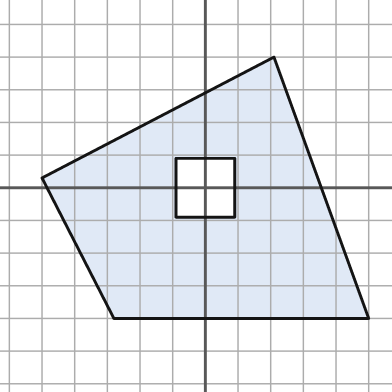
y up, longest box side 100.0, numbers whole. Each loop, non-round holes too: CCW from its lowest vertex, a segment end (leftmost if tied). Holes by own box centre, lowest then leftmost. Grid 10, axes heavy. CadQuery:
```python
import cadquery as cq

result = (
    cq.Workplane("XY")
    .moveTo(-28.0, -40.0)
    .lineTo(50.0, -40.0)
    .lineTo(21.0, 40.0)
    .lineTo(-50.0, 3.0)
    .close()
    .moveTo(-9.0, -9.0)
    .lineTo(9.0, -9.0)
    .lineTo(9.0, 9.0)
    .lineTo(-9.0, 9.0)
    .close()
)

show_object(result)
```